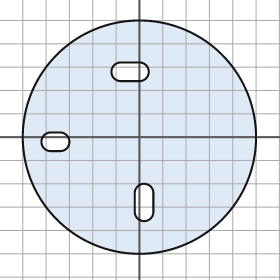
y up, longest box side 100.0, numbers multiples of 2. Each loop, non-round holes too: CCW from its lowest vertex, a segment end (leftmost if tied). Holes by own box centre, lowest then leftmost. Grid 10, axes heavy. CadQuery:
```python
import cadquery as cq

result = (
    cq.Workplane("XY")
    .moveTo(0.0, 0.0)
    .circle(50.0)
    .moveTo(-2.0, -32.0)
    .threePointArc((2.0, -36.0), (6.0, -32.0))
    .lineTo(6.0, -24.0)
    .threePointArc((2.0, -20.0), (-2.0, -24.0))
    .close()
    .moveTo(-38.0, -6.0)
    .lineTo(-34.0, -6.0)
    .threePointArc((-30.0, -2.0), (-34.0, 2.0))
    .lineTo(-38.0, 2.0)
    .threePointArc((-42.0, -2.0), (-38.0, -6.0))
    .close()
    .moveTo(-8.0, 24.0)
    .lineTo(0.0, 24.0)
    .threePointArc((4.0, 28.0), (0.0, 32.0))
    .lineTo(-8.0, 32.0)
    .threePointArc((-12.0, 28.0), (-8.0, 24.0))
    .close()
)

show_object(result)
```